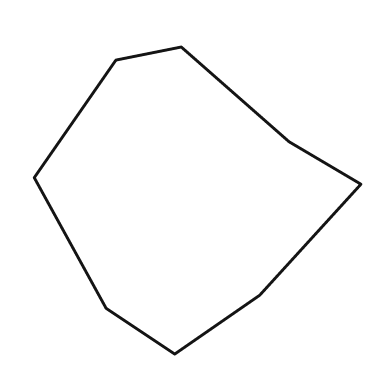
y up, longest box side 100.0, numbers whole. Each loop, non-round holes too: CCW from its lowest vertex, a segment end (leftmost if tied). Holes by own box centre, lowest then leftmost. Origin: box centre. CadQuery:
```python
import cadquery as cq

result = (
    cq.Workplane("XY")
    .moveTo(-7.0, -47.0)
    .lineTo(19.0, -29.0)
    .lineTo(50.0, 5.0)
    .lineTo(28.0, 18.0)
    .lineTo(-5.0, 47.0)
    .lineTo(-25.0, 43.0)
    .lineTo(-50.0, 7.0)
    .lineTo(-28.0, -33.0)
    .close()
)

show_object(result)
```